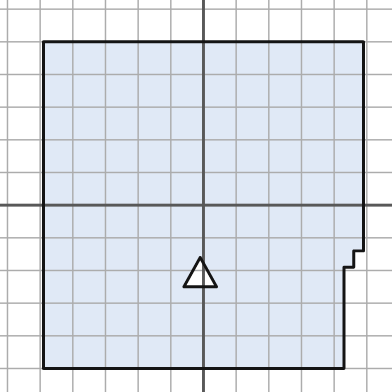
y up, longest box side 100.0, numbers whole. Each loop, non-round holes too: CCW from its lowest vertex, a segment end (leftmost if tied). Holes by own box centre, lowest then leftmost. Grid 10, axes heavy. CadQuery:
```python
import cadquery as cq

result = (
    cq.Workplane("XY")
    .moveTo(-49.0, -50.0)
    .lineTo(43.0, -50.0)
    .lineTo(43.0, -19.0)
    .lineTo(46.0, -19.0)
    .lineTo(46.0, -14.0)
    .lineTo(49.0, -14.0)
    .lineTo(49.0, 50.0)
    .lineTo(-49.0, 50.0)
    .close()
    .moveTo(-6.0, -25.0)
    .lineTo(4.0, -25.0)
    .lineTo(-1.0, -16.0)
    .close()
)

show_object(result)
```